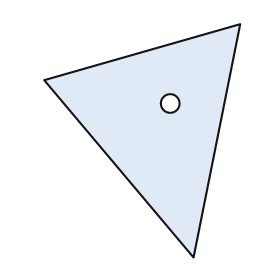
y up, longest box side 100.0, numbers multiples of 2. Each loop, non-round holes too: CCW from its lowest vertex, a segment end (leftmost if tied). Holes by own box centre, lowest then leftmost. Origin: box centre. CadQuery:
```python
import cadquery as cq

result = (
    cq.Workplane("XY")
    .moveTo(22.0, -50.0)
    .lineTo(42.0, 50.0)
    .lineTo(-42.0, 26.0)
    .close()
    .moveTo(12.0, 16.0)
    .circle(4.0)
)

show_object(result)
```